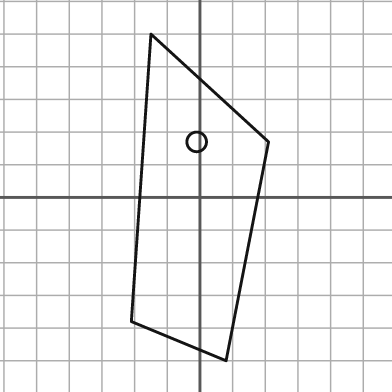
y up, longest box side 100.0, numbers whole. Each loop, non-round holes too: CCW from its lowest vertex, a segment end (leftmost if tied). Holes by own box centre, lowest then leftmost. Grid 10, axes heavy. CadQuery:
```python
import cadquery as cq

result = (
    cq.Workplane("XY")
    .moveTo(8.0, -50.0)
    .lineTo(21.0, 17.0)
    .lineTo(-15.0, 50.0)
    .lineTo(-21.0, -38.0)
    .close()
    .moveTo(-1.0, 17.0)
    .circle(3.0)
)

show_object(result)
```